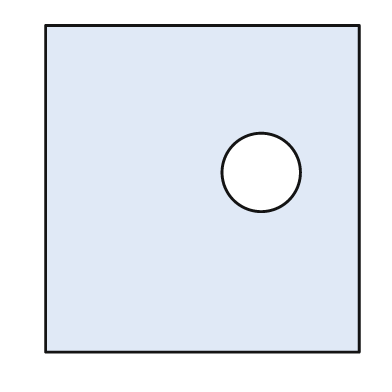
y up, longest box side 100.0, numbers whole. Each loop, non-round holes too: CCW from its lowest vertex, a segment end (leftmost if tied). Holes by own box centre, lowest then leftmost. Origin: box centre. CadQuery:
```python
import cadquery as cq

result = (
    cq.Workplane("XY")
    .moveTo(-48.0, -50.0)
    .lineTo(48.0, -50.0)
    .lineTo(48.0, 50.0)
    .lineTo(-48.0, 50.0)
    .close()
    .moveTo(18.0, 5.0)
    .circle(12.0)
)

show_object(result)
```